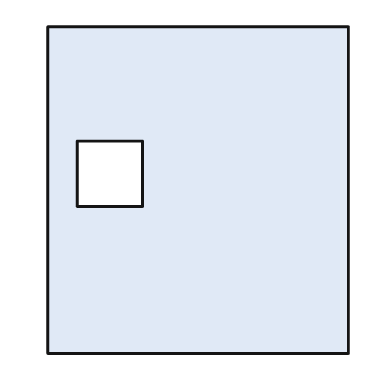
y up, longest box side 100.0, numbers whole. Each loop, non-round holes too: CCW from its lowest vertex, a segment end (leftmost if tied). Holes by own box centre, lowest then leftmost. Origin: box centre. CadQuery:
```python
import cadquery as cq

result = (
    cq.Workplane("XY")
    .moveTo(-46.0, -50.0)
    .lineTo(46.0, -50.0)
    .lineTo(46.0, 50.0)
    .lineTo(-46.0, 50.0)
    .close()
    .moveTo(-37.0, -5.0)
    .lineTo(-17.0, -5.0)
    .lineTo(-17.0, 15.0)
    .lineTo(-37.0, 15.0)
    .close()
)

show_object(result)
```